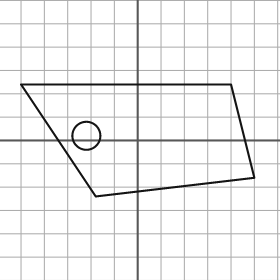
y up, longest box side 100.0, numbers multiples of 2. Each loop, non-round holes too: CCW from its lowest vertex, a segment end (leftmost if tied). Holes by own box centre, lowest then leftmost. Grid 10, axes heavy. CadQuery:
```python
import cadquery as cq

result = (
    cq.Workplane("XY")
    .moveTo(-18.0, -24.0)
    .lineTo(50.0, -16.0)
    .lineTo(40.0, 24.0)
    .lineTo(-50.0, 24.0)
    .close()
    .moveTo(-22.0, 2.0)
    .circle(6.0)
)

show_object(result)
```